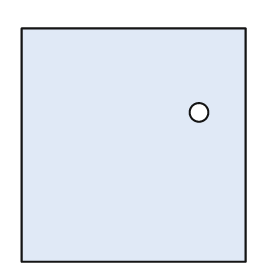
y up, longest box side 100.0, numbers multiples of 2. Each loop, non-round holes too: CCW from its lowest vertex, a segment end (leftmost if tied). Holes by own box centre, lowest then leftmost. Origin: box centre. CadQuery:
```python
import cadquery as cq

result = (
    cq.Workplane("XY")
    .moveTo(-48.0, -50.0)
    .lineTo(48.0, -50.0)
    .lineTo(48.0, 50.0)
    .lineTo(-48.0, 50.0)
    .close()
    .moveTo(28.0, 14.0)
    .circle(4.0)
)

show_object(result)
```